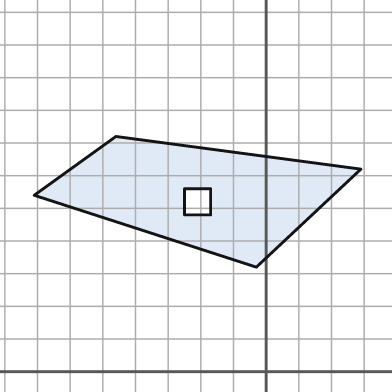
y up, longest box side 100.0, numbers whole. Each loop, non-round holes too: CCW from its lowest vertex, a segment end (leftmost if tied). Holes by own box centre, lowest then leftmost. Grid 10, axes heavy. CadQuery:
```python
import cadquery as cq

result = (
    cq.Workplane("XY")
    .moveTo(-3.0, 32.0)
    .lineTo(29.0, 62.0)
    .lineTo(-46.0, 72.0)
    .lineTo(-71.0, 54.0)
    .close()
    .moveTo(-25.0, 48.0)
    .lineTo(-17.0, 48.0)
    .lineTo(-17.0, 56.0)
    .lineTo(-25.0, 56.0)
    .close()
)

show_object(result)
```